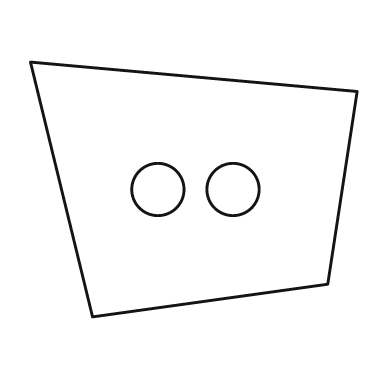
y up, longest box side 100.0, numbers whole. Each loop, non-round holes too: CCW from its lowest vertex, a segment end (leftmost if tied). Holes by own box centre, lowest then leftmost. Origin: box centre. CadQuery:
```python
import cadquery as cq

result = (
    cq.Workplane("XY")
    .moveTo(-31.0, -39.0)
    .lineTo(41.0, -29.0)
    .lineTo(50.0, 30.0)
    .lineTo(-50.0, 39.0)
    .close()
    .moveTo(-11.0, 0.0)
    .circle(8.0)
    .moveTo(12.0, 0.0)
    .circle(8.0)
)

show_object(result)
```